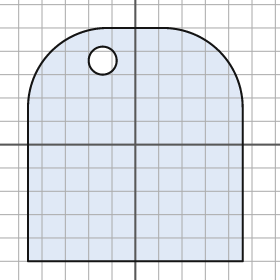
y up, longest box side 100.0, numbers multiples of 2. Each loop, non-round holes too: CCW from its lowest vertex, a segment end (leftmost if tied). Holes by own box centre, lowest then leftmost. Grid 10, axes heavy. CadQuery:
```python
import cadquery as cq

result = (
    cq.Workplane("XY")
    .moveTo(-46.0, -50.0)
    .lineTo(46.0, -50.0)
    .lineTo(46.0, 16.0)
    .threePointArc((36.0, 40.0), (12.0, 50.0))
    .lineTo(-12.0, 50.0)
    .threePointArc((-36.0, 40.0), (-46.0, 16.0))
    .close()
    .moveTo(-14.0, 36.0)
    .circle(6.0)
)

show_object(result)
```